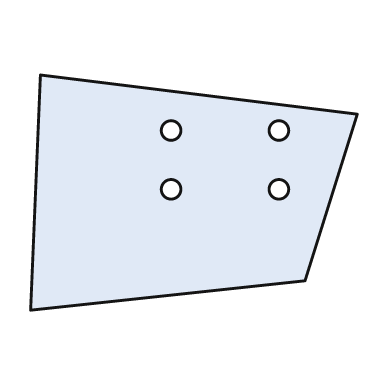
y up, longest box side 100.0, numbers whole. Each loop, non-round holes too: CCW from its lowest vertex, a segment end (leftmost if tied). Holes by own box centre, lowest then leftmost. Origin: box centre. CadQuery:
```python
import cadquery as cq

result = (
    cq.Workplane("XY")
    .moveTo(-50.0, -36.0)
    .lineTo(34.0, -27.0)
    .lineTo(50.0, 24.0)
    .lineTo(-47.0, 36.0)
    .close()
    .moveTo(-7.0, 1.0)
    .circle(3.0)
    .moveTo(26.0, 1.0)
    .circle(3.0)
    .moveTo(-7.0, 19.0)
    .circle(3.0)
    .moveTo(26.0, 19.0)
    .circle(3.0)
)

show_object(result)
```